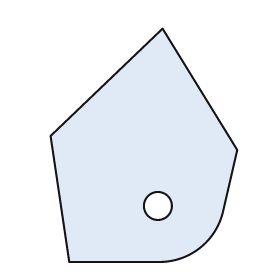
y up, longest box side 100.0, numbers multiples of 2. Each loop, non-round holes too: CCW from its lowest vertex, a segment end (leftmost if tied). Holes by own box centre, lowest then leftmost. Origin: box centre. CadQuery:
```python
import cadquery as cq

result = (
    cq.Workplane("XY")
    .moveTo(-32.0, -50.0)
    .lineTo(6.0, -50.0)
    .threePointArc((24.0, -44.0), (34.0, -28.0))
    .lineTo(40.0, -2.0)
    .lineTo(8.0, 50.0)
    .lineTo(-40.0, 4.0)
    .close()
    .moveTo(6.0, -26.0)
    .circle(6.0)
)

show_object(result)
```